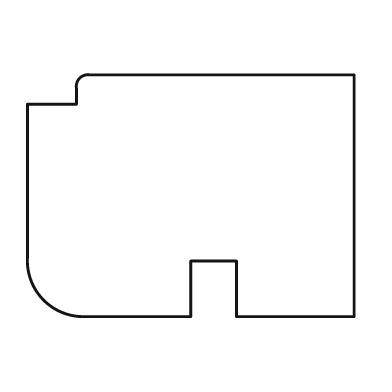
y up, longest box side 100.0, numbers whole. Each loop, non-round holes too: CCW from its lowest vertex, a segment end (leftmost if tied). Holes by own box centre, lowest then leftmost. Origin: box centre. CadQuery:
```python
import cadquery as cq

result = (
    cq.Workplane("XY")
    .moveTo(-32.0, -37.0)
    .lineTo(0.0, -37.0)
    .lineTo(0.0, -20.0)
    .lineTo(14.0, -20.0)
    .lineTo(14.0, -37.0)
    .lineTo(50.0, -37.0)
    .lineTo(50.0, 37.0)
    .lineTo(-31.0, 37.0)
    .threePointArc((-34.0, 36.0), (-35.0, 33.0))
    .lineTo(-35.0, 28.0)
    .lineTo(-50.0, 28.0)
    .lineTo(-50.0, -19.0)
    .threePointArc((-45.0, -32.0), (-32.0, -37.0))
    .close()
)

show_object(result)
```